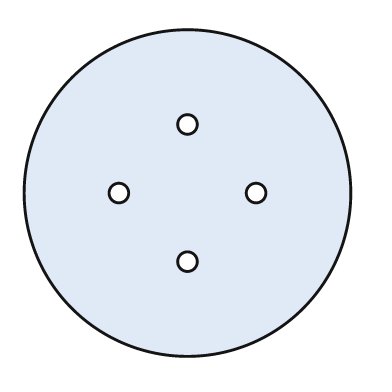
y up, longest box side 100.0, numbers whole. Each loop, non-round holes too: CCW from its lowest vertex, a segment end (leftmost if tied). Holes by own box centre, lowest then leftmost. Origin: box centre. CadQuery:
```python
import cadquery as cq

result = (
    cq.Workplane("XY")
    .moveTo(0.0, 0.0)
    .circle(50.0)
    .moveTo(0.0, -21.0)
    .circle(3.0)
    .moveTo(-21.0, 0.0)
    .circle(3.0)
    .moveTo(21.0, 0.0)
    .circle(3.0)
    .moveTo(0.0, 21.0)
    .circle(3.0)
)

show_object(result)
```